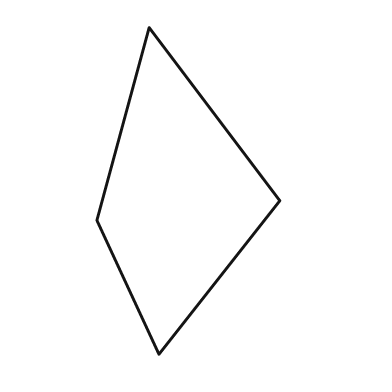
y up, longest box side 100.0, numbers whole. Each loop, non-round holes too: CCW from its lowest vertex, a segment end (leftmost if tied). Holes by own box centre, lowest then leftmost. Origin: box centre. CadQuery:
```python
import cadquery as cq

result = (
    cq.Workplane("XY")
    .moveTo(-9.0, -50.0)
    .lineTo(28.0, -3.0)
    .lineTo(-12.0, 50.0)
    .lineTo(-28.0, -9.0)
    .close()
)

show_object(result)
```